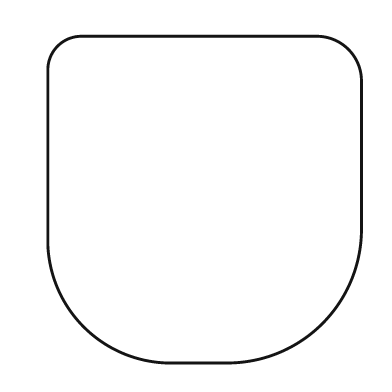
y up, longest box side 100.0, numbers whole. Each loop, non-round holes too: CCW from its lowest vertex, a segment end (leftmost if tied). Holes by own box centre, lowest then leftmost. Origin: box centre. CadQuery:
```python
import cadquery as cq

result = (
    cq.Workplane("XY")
    .moveTo(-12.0, -50.0)
    .lineTo(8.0, -50.0)
    .threePointArc((36.0, -38.0), (48.0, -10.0))
    .lineTo(48.0, 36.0)
    .threePointArc((44.0, 46.0), (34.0, 50.0))
    .lineTo(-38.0, 50.0)
    .threePointArc((-45.0, 47.0), (-48.0, 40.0))
    .lineTo(-48.0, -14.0)
    .threePointArc((-37.0, -39.0), (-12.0, -50.0))
    .close()
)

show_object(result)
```